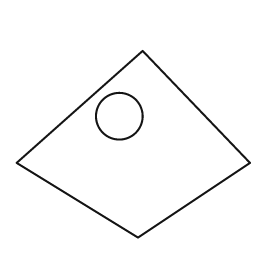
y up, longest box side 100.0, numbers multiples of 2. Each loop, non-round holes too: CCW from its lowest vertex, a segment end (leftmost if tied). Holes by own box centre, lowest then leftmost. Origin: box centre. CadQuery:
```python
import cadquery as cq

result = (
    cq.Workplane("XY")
    .moveTo(2.0, -40.0)
    .lineTo(50.0, -8.0)
    .lineTo(4.0, 40.0)
    .lineTo(-50.0, -8.0)
    .close()
    .moveTo(-6.0, 12.0)
    .circle(10.0)
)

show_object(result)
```